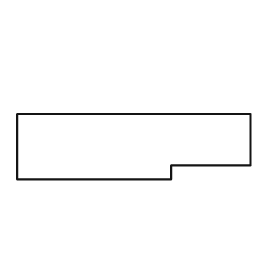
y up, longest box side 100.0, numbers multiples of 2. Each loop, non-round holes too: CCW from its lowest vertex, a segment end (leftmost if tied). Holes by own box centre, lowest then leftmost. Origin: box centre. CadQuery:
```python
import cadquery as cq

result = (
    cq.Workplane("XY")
    .moveTo(-50.0, -14.0)
    .lineTo(16.0, -14.0)
    .lineTo(16.0, -8.0)
    .lineTo(50.0, -8.0)
    .lineTo(50.0, 14.0)
    .lineTo(-50.0, 14.0)
    .close()
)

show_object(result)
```